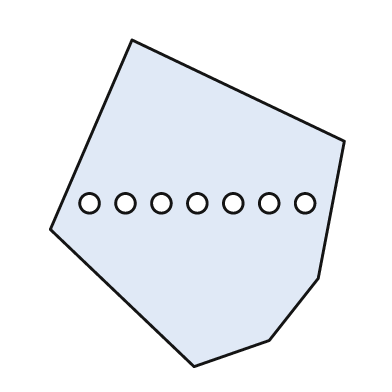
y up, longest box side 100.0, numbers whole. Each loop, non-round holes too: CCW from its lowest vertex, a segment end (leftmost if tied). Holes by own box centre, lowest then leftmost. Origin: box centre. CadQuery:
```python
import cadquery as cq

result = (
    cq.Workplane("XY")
    .moveTo(-1.0, -50.0)
    .lineTo(22.0, -42.0)
    .lineTo(37.0, -23.0)
    .lineTo(45.0, 19.0)
    .lineTo(-20.0, 50.0)
    .lineTo(-45.0, -8.0)
    .close()
    .moveTo(-33.0, 0.0)
    .circle(3.0)
    .moveTo(-22.0, 0.0)
    .circle(3.0)
    .moveTo(-11.0, 0.0)
    .circle(3.0)
    .moveTo(0.0, 0.0)
    .circle(3.0)
    .moveTo(11.0, 0.0)
    .circle(3.0)
    .moveTo(22.0, 0.0)
    .circle(3.0)
    .moveTo(33.0, 0.0)
    .circle(3.0)
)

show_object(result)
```